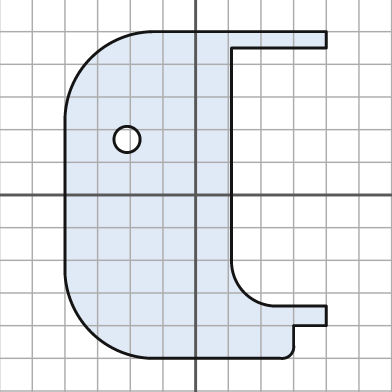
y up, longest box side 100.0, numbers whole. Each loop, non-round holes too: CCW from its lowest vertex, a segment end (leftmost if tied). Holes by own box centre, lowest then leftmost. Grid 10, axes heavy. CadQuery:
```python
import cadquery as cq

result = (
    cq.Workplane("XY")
    .moveTo(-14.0, -50.0)
    .lineTo(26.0, -50.0)
    .threePointArc((29.0, -49.0), (30.0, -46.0))
    .lineTo(30.0, -40.0)
    .lineTo(40.0, -40.0)
    .lineTo(40.0, -34.0)
    .lineTo(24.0, -34.0)
    .threePointArc((15.0, -30.0), (11.0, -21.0))
    .lineTo(11.0, 45.0)
    .lineTo(40.0, 45.0)
    .lineTo(40.0, 50.0)
    .lineTo(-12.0, 50.0)
    .threePointArc((-32.0, 42.0), (-40.0, 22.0))
    .lineTo(-40.0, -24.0)
    .threePointArc((-32.0, -42.0), (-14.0, -50.0))
    .close()
    .moveTo(-21.0, 17.0)
    .circle(4.0)
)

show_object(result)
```